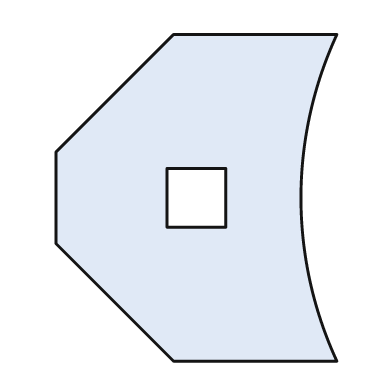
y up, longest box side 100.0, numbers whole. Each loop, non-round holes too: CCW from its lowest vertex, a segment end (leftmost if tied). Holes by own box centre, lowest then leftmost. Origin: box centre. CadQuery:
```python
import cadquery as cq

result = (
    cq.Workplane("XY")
    .moveTo(-7.0, -50.0)
    .lineTo(43.0, -50.0)
    .threePointArc((32.0, 0.0), (43.0, 50.0))
    .lineTo(-7.0, 50.0)
    .lineTo(-43.0, 14.0)
    .lineTo(-43.0, -14.0)
    .close()
    .moveTo(-9.0, -9.0)
    .lineTo(9.0, -9.0)
    .lineTo(9.0, 9.0)
    .lineTo(-9.0, 9.0)
    .close()
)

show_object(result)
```